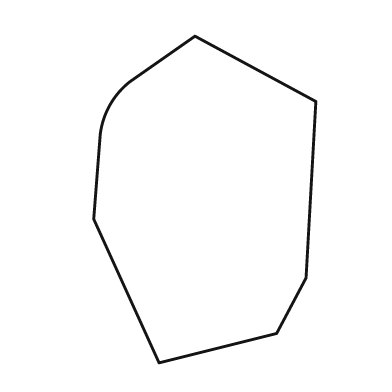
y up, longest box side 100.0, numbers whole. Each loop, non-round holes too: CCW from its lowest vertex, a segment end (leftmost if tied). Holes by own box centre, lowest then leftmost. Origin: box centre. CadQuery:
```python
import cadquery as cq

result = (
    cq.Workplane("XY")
    .moveTo(-14.0, -50.0)
    .lineTo(22.0, -41.0)
    .lineTo(31.0, -24.0)
    .lineTo(34.0, 30.0)
    .lineTo(-3.0, 50.0)
    .lineTo(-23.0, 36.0)
    .threePointArc((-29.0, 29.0), (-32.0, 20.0))
    .lineTo(-34.0, -6.0)
    .close()
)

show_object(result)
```